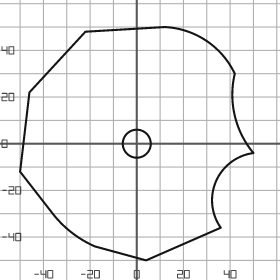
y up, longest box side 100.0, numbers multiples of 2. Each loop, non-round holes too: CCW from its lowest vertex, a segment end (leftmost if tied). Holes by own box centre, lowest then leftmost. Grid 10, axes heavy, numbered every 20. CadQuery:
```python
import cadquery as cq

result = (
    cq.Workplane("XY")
    .moveTo(4.0, -50.0)
    .lineTo(36.0, -36.0)
    .threePointArc((34.0, -16.0), (50.0, -4.0))
    .threePointArc((42.0, 12.0), (42.0, 30.0))
    .threePointArc((30.0, 44.0), (12.0, 50.0))
    .lineTo(-22.0, 48.0)
    .lineTo(-46.0, 22.0)
    .lineTo(-50.0, -12.0)
    .lineTo(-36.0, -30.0)
    .threePointArc((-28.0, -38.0), (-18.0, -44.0))
    .close()
    .moveTo(0.0, 0.0)
    .circle(6.0)
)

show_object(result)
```